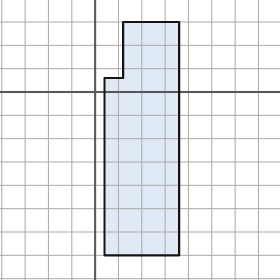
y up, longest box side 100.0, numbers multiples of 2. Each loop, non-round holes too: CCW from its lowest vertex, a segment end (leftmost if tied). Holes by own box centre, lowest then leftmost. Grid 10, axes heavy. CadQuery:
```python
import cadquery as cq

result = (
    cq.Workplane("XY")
    .moveTo(4.0, -70.0)
    .lineTo(36.0, -70.0)
    .lineTo(36.0, 30.0)
    .lineTo(12.0, 30.0)
    .lineTo(12.0, 6.0)
    .lineTo(4.0, 6.0)
    .close()
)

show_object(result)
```